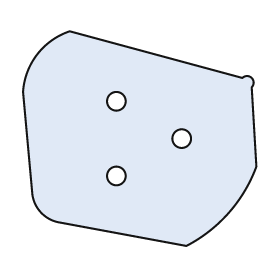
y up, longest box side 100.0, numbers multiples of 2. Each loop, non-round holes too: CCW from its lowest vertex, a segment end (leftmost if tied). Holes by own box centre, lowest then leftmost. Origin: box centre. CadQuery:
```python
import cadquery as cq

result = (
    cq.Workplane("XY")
    .moveTo(20.0, -46.0)
    .threePointArc((38.0, -32.0), (50.0, -12.0))
    .lineTo(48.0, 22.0)
    .threePointArc((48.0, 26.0), (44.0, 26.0))
    .lineTo(-30.0, 46.0)
    .threePointArc((-44.0, 36.0), (-50.0, 20.0))
    .lineTo(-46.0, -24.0)
    .threePointArc((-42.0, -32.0), (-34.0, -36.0))
    .close()
    .moveTo(-10.0, -16.0)
    .circle(4.0)
    .moveTo(18.0, 0.0)
    .circle(4.0)
    .moveTo(-10.0, 16.0)
    .circle(4.0)
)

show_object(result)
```